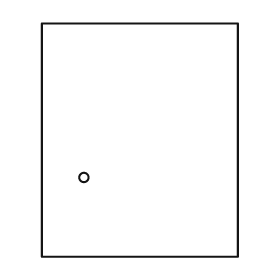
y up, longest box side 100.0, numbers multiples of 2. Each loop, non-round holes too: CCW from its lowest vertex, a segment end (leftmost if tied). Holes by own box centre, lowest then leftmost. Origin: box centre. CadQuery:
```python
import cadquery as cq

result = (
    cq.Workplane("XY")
    .moveTo(-42.0, -50.0)
    .lineTo(42.0, -50.0)
    .lineTo(42.0, 50.0)
    .lineTo(-42.0, 50.0)
    .close()
    .moveTo(-24.0, -16.0)
    .circle(2.0)
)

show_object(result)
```